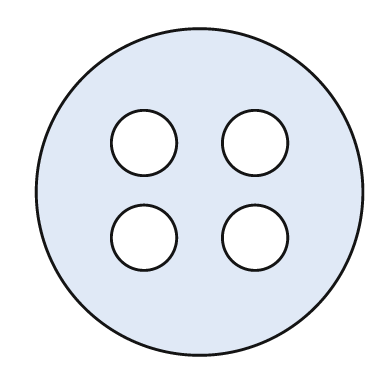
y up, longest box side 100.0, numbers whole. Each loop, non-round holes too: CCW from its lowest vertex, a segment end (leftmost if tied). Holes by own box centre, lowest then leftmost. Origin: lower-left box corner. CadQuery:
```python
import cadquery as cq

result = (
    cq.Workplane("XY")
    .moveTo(50.0, 50.0)
    .circle(50.0)
    .moveTo(33.0, 36.0)
    .circle(10.0)
    .moveTo(67.0, 36.0)
    .circle(10.0)
    .moveTo(33.0, 65.0)
    .circle(10.0)
    .moveTo(67.0, 65.0)
    .circle(10.0)
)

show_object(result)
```